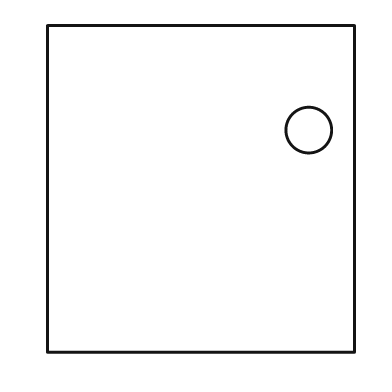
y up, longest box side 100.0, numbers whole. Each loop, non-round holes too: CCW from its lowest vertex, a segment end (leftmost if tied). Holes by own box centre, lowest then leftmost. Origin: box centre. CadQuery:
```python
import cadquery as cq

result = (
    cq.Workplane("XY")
    .moveTo(-47.0, -50.0)
    .lineTo(47.0, -50.0)
    .lineTo(47.0, 50.0)
    .lineTo(-47.0, 50.0)
    .close()
    .moveTo(33.0, 18.0)
    .circle(7.0)
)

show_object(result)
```